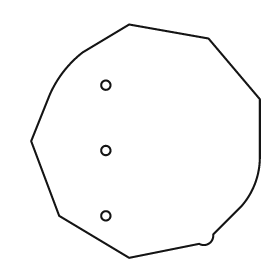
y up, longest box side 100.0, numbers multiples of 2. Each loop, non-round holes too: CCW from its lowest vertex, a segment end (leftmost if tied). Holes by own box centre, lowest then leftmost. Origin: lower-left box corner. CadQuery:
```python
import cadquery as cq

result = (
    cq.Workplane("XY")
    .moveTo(42.0, 0.0)
    .lineTo(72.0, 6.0)
    .threePointArc((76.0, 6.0), (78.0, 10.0))
    .lineTo(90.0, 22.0)
    .threePointArc((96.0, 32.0), (98.0, 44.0))
    .lineTo(98.0, 68.0)
    .lineTo(76.0, 94.0)
    .lineTo(42.0, 100.0)
    .lineTo(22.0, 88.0)
    .threePointArc((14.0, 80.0), (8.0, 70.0))
    .lineTo(0.0, 50.0)
    .lineTo(12.0, 18.0)
    .close()
    .moveTo(32.0, 18.0)
    .circle(2.0)
    .moveTo(32.0, 46.0)
    .circle(2.0)
    .moveTo(32.0, 74.0)
    .circle(2.0)
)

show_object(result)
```